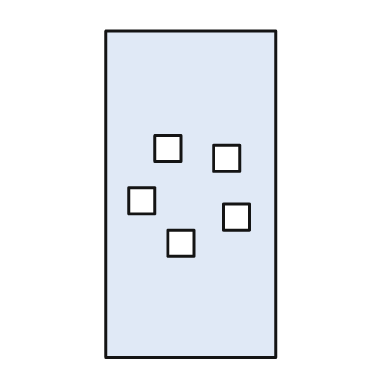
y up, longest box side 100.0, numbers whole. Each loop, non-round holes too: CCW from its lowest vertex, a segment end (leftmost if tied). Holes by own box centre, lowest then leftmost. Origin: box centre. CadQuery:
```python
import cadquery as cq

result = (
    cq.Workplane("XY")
    .moveTo(-26.0, -50.0)
    .lineTo(26.0, -50.0)
    .lineTo(26.0, 50.0)
    .lineTo(-26.0, 50.0)
    .close()
    .moveTo(-7.0, -19.0)
    .lineTo(1.0, -19.0)
    .lineTo(1.0, -11.0)
    .lineTo(-7.0, -11.0)
    .close()
    .moveTo(10.0, -11.0)
    .lineTo(18.0, -11.0)
    .lineTo(18.0, -3.0)
    .lineTo(10.0, -3.0)
    .close()
    .moveTo(-19.0, -6.0)
    .lineTo(-11.0, -6.0)
    .lineTo(-11.0, 2.0)
    .lineTo(-19.0, 2.0)
    .close()
    .moveTo(7.0, 7.0)
    .lineTo(15.0, 7.0)
    .lineTo(15.0, 15.0)
    .lineTo(7.0, 15.0)
    .close()
    .moveTo(-11.0, 10.0)
    .lineTo(-3.0, 10.0)
    .lineTo(-3.0, 18.0)
    .lineTo(-11.0, 18.0)
    .close()
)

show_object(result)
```